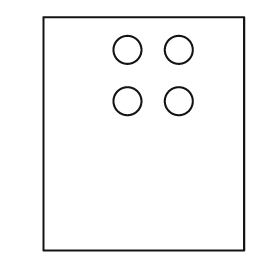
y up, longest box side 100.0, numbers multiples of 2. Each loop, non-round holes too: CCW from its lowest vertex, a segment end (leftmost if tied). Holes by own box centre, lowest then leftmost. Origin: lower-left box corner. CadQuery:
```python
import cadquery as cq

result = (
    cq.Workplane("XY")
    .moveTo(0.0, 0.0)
    .lineTo(86.0, 0.0)
    .lineTo(86.0, 100.0)
    .lineTo(0.0, 100.0)
    .close()
    .moveTo(36.0, 64.0)
    .circle(6.0)
    .moveTo(58.0, 64.0)
    .circle(6.0)
    .moveTo(36.0, 86.0)
    .circle(6.0)
    .moveTo(58.0, 86.0)
    .circle(6.0)
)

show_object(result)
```